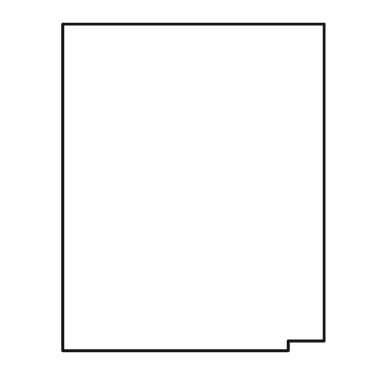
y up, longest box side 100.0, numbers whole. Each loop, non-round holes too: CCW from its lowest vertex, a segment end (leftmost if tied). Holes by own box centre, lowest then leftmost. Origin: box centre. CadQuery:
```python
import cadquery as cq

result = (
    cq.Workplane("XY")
    .moveTo(-40.0, -50.0)
    .lineTo(29.0, -50.0)
    .lineTo(29.0, -47.0)
    .lineTo(40.0, -47.0)
    .lineTo(40.0, 50.0)
    .lineTo(-40.0, 50.0)
    .close()
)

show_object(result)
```